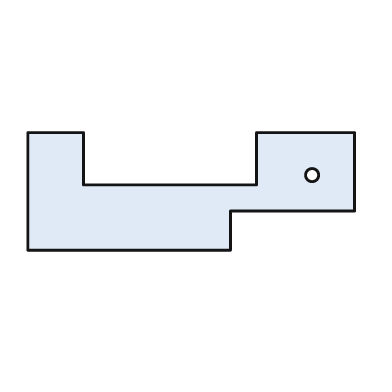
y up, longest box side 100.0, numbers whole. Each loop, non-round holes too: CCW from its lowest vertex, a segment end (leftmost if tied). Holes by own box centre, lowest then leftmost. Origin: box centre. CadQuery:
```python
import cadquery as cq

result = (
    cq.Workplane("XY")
    .moveTo(-50.0, -18.0)
    .lineTo(12.0, -18.0)
    .lineTo(12.0, -6.0)
    .lineTo(50.0, -6.0)
    .lineTo(50.0, 18.0)
    .lineTo(20.0, 18.0)
    .lineTo(20.0, 2.0)
    .lineTo(-33.0, 2.0)
    .lineTo(-33.0, 18.0)
    .lineTo(-50.0, 18.0)
    .close()
    .moveTo(37.0, 5.0)
    .circle(2.0)
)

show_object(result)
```